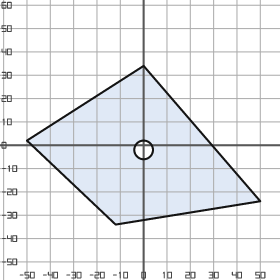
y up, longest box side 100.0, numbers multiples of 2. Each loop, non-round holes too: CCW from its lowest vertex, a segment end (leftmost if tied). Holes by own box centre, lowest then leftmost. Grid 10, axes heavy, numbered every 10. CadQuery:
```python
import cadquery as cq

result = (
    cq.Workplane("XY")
    .moveTo(-12.0, -34.0)
    .lineTo(50.0, -24.0)
    .lineTo(0.0, 34.0)
    .lineTo(-50.0, 2.0)
    .close()
    .moveTo(0.0, -2.0)
    .circle(4.0)
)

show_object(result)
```